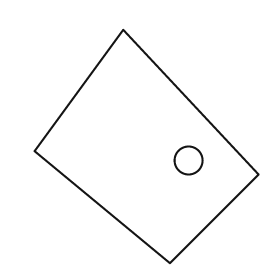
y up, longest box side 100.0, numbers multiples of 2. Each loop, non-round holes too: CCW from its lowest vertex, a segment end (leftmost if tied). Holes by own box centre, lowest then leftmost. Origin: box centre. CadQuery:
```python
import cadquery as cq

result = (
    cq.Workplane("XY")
    .moveTo(10.0, -50.0)
    .lineTo(48.0, -12.0)
    .lineTo(-10.0, 50.0)
    .lineTo(-48.0, -2.0)
    .close()
    .moveTo(18.0, -6.0)
    .circle(6.0)
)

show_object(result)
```